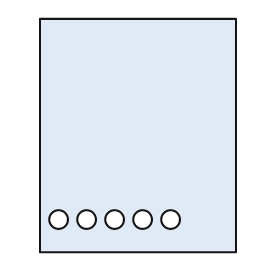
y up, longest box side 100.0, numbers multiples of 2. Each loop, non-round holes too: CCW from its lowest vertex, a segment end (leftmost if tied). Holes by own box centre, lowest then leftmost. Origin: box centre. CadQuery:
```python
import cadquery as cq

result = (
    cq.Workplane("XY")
    .moveTo(-42.0, -50.0)
    .lineTo(42.0, -50.0)
    .lineTo(42.0, 50.0)
    .lineTo(-42.0, 50.0)
    .close()
    .moveTo(-34.0, -36.0)
    .circle(4.0)
    .moveTo(-22.0, -36.0)
    .circle(4.0)
    .moveTo(-10.0, -36.0)
    .circle(4.0)
    .moveTo(2.0, -36.0)
    .circle(4.0)
    .moveTo(14.0, -36.0)
    .circle(4.0)
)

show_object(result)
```